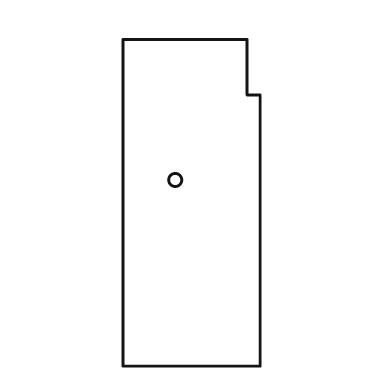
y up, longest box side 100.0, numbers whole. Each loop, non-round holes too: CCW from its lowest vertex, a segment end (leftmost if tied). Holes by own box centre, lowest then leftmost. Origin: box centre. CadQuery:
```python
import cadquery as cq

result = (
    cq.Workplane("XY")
    .moveTo(-21.0, -50.0)
    .lineTo(21.0, -50.0)
    .lineTo(21.0, 33.0)
    .lineTo(17.0, 33.0)
    .lineTo(17.0, 50.0)
    .lineTo(-21.0, 50.0)
    .close()
    .moveTo(-5.0, 7.0)
    .circle(2.0)
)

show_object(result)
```